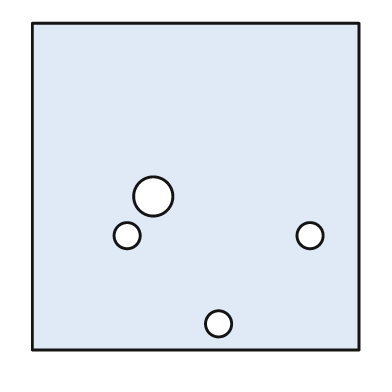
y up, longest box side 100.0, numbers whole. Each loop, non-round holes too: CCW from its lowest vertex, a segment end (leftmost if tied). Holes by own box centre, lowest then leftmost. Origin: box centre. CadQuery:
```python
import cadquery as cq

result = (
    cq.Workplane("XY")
    .moveTo(-50.0, -50.0)
    .lineTo(50.0, -50.0)
    .lineTo(50.0, 50.0)
    .lineTo(-50.0, 50.0)
    .close()
    .moveTo(7.0, -42.0)
    .circle(4.0)
    .moveTo(-21.0, -15.0)
    .circle(4.0)
    .moveTo(35.0, -15.0)
    .circle(4.0)
    .moveTo(-13.0, -3.0)
    .circle(6.0)
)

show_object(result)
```